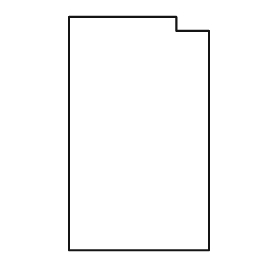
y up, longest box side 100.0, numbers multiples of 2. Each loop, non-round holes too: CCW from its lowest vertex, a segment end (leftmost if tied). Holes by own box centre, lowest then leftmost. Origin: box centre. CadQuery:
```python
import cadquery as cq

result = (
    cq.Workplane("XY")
    .moveTo(-30.0, -50.0)
    .lineTo(30.0, -50.0)
    .lineTo(30.0, 44.0)
    .lineTo(16.0, 44.0)
    .lineTo(16.0, 50.0)
    .lineTo(-30.0, 50.0)
    .close()
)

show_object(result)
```